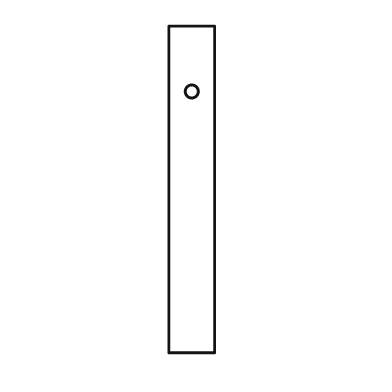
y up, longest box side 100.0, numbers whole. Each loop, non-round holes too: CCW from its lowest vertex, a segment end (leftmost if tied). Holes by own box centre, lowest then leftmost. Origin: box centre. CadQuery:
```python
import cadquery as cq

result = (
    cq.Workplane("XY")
    .moveTo(-7.0, -50.0)
    .lineTo(7.0, -50.0)
    .lineTo(7.0, 50.0)
    .lineTo(-7.0, 50.0)
    .close()
    .moveTo(0.0, 30.0)
    .circle(2.0)
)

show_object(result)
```